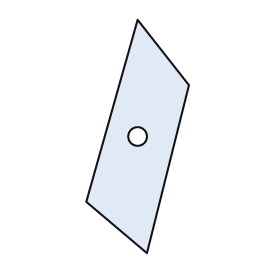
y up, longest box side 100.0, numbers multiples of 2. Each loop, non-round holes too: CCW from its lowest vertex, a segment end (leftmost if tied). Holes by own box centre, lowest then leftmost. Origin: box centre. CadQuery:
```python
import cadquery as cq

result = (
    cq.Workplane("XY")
    .moveTo(4.0, -50.0)
    .lineTo(22.0, 22.0)
    .lineTo(0.0, 50.0)
    .lineTo(-22.0, -28.0)
    .close()
    .moveTo(0.0, 0.0)
    .circle(4.0)
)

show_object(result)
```